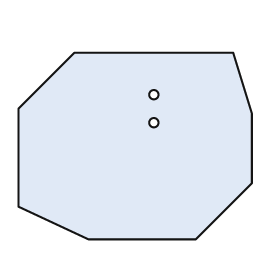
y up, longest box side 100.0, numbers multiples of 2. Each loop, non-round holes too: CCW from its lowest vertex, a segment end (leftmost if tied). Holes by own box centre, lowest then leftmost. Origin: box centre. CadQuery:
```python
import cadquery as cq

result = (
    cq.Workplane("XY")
    .moveTo(-20.0, -40.0)
    .lineTo(26.0, -40.0)
    .lineTo(50.0, -16.0)
    .lineTo(50.0, 14.0)
    .lineTo(42.0, 40.0)
    .lineTo(-26.0, 40.0)
    .lineTo(-50.0, 16.0)
    .lineTo(-50.0, -26.0)
    .close()
    .moveTo(8.0, 10.0)
    .circle(2.0)
    .moveTo(8.0, 22.0)
    .circle(2.0)
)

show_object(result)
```